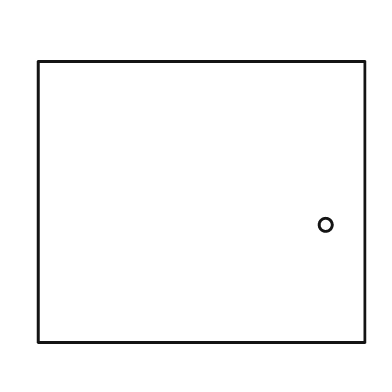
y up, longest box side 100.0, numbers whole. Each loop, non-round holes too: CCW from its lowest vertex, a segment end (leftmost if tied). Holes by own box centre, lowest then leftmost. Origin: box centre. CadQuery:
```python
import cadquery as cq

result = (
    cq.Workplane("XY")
    .moveTo(-50.0, -43.0)
    .lineTo(50.0, -43.0)
    .lineTo(50.0, 43.0)
    .lineTo(-50.0, 43.0)
    .close()
    .moveTo(38.0, -7.0)
    .circle(2.0)
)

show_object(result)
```